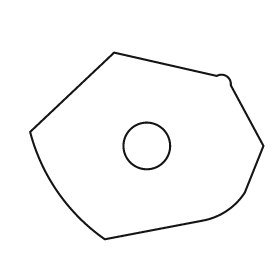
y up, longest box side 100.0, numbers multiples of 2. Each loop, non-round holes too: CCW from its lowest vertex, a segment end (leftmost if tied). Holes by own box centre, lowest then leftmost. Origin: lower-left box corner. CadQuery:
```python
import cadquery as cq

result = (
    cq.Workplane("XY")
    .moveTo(32.0, 0.0)
    .lineTo(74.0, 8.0)
    .threePointArc((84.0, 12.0), (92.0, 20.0))
    .lineTo(100.0, 40.0)
    .lineTo(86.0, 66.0)
    .threePointArc((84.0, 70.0), (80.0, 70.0))
    .lineTo(36.0, 80.0)
    .lineTo(0.0, 46.0)
    .threePointArc((12.0, 20.0), (32.0, 0.0))
    .close()
    .moveTo(50.0, 40.0)
    .circle(10.0)
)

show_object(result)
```